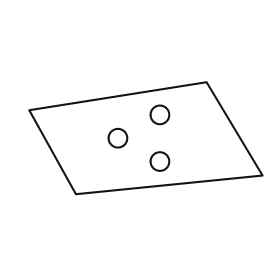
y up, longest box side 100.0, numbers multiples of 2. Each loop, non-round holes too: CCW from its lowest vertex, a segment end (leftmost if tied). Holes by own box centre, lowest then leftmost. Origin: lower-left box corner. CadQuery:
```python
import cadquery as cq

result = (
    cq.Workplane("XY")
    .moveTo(20.0, 0.0)
    .lineTo(100.0, 8.0)
    .lineTo(76.0, 48.0)
    .lineTo(0.0, 36.0)
    .close()
    .moveTo(56.0, 14.0)
    .circle(4.0)
    .moveTo(38.0, 24.0)
    .circle(4.0)
    .moveTo(56.0, 34.0)
    .circle(4.0)
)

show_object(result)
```